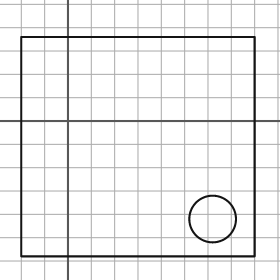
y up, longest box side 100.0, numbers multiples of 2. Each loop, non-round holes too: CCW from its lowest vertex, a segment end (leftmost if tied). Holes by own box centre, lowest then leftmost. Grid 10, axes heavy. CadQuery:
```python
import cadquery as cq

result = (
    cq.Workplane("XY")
    .moveTo(-20.0, -58.0)
    .lineTo(80.0, -58.0)
    .lineTo(80.0, 36.0)
    .lineTo(-20.0, 36.0)
    .close()
    .moveTo(62.0, -42.0)
    .circle(10.0)
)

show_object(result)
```